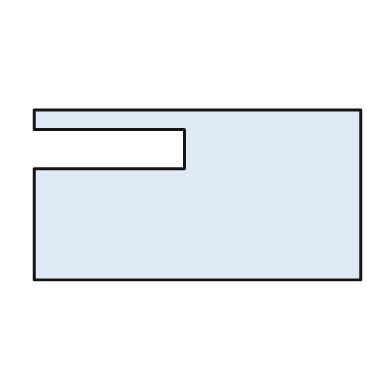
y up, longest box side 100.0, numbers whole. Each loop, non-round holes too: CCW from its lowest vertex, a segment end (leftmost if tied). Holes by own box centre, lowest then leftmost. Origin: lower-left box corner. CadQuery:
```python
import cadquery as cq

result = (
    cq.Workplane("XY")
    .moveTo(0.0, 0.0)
    .lineTo(100.0, 0.0)
    .lineTo(100.0, 52.0)
    .lineTo(0.0, 52.0)
    .lineTo(0.0, 46.0)
    .lineTo(46.0, 46.0)
    .lineTo(46.0, 34.0)
    .lineTo(0.0, 34.0)
    .close()
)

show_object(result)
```